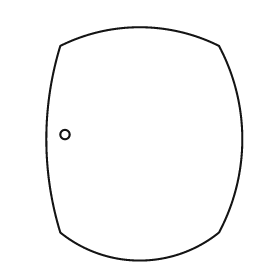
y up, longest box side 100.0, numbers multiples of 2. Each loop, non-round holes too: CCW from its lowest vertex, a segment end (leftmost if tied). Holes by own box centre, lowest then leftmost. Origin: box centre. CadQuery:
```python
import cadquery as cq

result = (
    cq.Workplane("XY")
    .moveTo(-36.0, -38.0)
    .threePointArc((-2.0, -50.0), (32.0, -38.0))
    .threePointArc((42.0, 2.0), (32.0, 42.0))
    .threePointArc((-2.0, 50.0), (-36.0, 42.0))
    .threePointArc((-42.0, 2.0), (-36.0, -38.0))
    .close()
    .moveTo(-34.0, 4.0)
    .circle(2.0)
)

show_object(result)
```